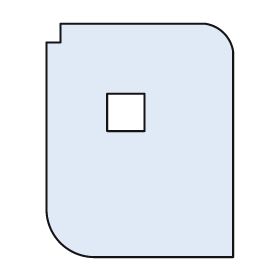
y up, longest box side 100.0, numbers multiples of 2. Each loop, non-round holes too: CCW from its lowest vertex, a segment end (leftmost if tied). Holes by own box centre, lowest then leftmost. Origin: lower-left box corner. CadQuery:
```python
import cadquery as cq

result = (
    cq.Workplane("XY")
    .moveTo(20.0, 0.0)
    .lineTo(80.0, 0.0)
    .lineTo(80.0, 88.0)
    .threePointArc((76.0, 96.0), (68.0, 100.0))
    .lineTo(6.0, 100.0)
    .lineTo(6.0, 92.0)
    .lineTo(0.0, 92.0)
    .lineTo(0.0, 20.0)
    .threePointArc((6.0, 6.0), (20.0, 0.0))
    .close()
    .moveTo(26.0, 54.0)
    .lineTo(42.0, 54.0)
    .lineTo(42.0, 70.0)
    .lineTo(26.0, 70.0)
    .close()
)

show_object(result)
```